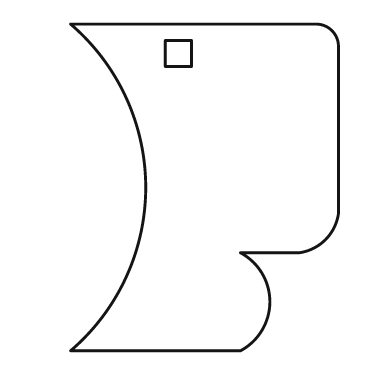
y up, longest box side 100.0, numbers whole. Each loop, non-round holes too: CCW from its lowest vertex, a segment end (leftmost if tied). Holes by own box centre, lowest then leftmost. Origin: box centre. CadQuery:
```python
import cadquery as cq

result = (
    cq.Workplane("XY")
    .moveTo(-41.0, -50.0)
    .lineTo(11.0, -50.0)
    .threePointArc((20.0, -35.0), (11.0, -20.0))
    .lineTo(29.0, -20.0)
    .threePointArc((37.0, -16.0), (41.0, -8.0))
    .lineTo(41.0, 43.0)
    .threePointArc((39.0, 48.0), (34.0, 50.0))
    .lineTo(-41.0, 50.0)
    .threePointArc((-18.0, 0.0), (-41.0, -50.0))
    .close()
    .moveTo(-12.0, 37.0)
    .lineTo(-4.0, 37.0)
    .lineTo(-4.0, 45.0)
    .lineTo(-12.0, 45.0)
    .close()
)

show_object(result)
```